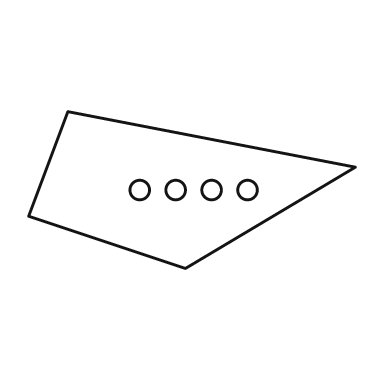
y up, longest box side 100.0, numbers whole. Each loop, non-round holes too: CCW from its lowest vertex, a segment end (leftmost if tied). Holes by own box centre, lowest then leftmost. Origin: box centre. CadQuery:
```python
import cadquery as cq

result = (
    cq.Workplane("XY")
    .moveTo(-2.0, -24.0)
    .lineTo(50.0, 7.0)
    .lineTo(-38.0, 24.0)
    .lineTo(-50.0, -8.0)
    .close()
    .moveTo(-16.0, 0.0)
    .circle(3.0)
    .moveTo(-5.0, 0.0)
    .circle(3.0)
    .moveTo(6.0, 0.0)
    .circle(3.0)
    .moveTo(17.0, 0.0)
    .circle(3.0)
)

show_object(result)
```